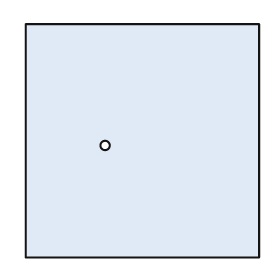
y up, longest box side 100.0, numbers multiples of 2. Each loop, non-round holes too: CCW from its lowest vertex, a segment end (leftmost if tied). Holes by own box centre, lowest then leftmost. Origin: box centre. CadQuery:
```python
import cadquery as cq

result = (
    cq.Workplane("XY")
    .moveTo(-50.0, -50.0)
    .lineTo(50.0, -50.0)
    .lineTo(50.0, 50.0)
    .lineTo(-50.0, 50.0)
    .close()
    .moveTo(-16.0, -2.0)
    .circle(2.0)
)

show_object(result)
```